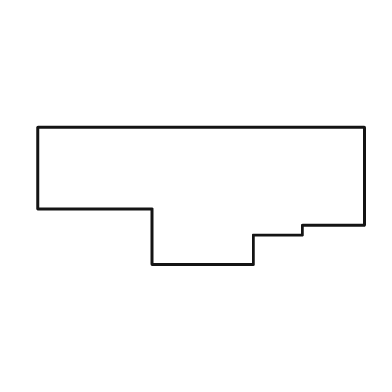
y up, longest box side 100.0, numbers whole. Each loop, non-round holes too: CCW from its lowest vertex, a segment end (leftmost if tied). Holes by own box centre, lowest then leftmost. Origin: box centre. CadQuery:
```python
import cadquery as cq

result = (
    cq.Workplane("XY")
    .moveTo(-15.0, -21.0)
    .lineTo(16.0, -21.0)
    .lineTo(16.0, -12.0)
    .lineTo(31.0, -12.0)
    .lineTo(31.0, -9.0)
    .lineTo(50.0, -9.0)
    .lineTo(50.0, 21.0)
    .lineTo(-50.0, 21.0)
    .lineTo(-50.0, -4.0)
    .lineTo(-15.0, -4.0)
    .close()
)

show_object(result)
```